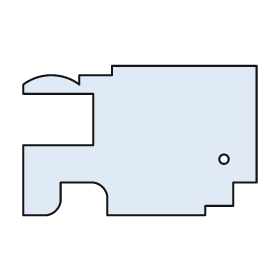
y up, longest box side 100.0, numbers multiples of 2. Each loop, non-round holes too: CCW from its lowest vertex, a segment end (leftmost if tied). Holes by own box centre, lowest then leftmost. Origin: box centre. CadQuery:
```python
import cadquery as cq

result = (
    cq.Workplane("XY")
    .moveTo(-50.0, -32.0)
    .lineTo(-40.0, -32.0)
    .threePointArc((-36.0, -30.0), (-34.0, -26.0))
    .lineTo(-34.0, -18.0)
    .lineTo(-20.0, -18.0)
    .threePointArc((-16.0, -20.0), (-14.0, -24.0))
    .lineTo(-14.0, -32.0)
    .lineTo(28.0, -32.0)
    .lineTo(28.0, -28.0)
    .lineTo(40.0, -28.0)
    .lineTo(40.0, -18.0)
    .lineTo(50.0, -18.0)
    .lineTo(50.0, 32.0)
    .lineTo(-12.0, 32.0)
    .lineTo(-12.0, 28.0)
    .lineTo(-26.0, 28.0)
    .lineTo(-26.0, 24.0)
    .threePointArc((-38.0, 28.0), (-50.0, 24.0))
    .lineTo(-50.0, 20.0)
    .lineTo(-20.0, 20.0)
    .lineTo(-20.0, -2.0)
    .lineTo(-50.0, -2.0)
    .close()
    .moveTo(36.0, -8.0)
    .circle(2.0)
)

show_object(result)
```